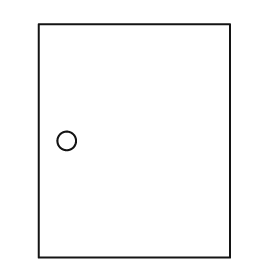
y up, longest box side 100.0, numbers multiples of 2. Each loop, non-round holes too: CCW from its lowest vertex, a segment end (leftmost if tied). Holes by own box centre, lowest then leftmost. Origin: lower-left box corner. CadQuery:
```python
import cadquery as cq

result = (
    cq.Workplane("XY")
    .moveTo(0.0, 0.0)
    .lineTo(82.0, 0.0)
    .lineTo(82.0, 100.0)
    .lineTo(0.0, 100.0)
    .close()
    .moveTo(12.0, 50.0)
    .circle(4.0)
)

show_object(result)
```